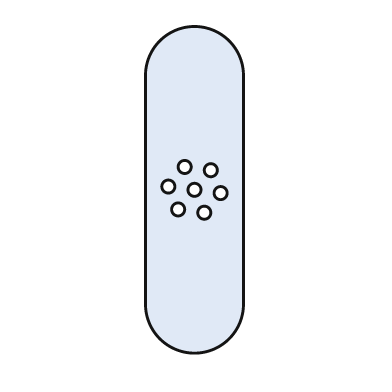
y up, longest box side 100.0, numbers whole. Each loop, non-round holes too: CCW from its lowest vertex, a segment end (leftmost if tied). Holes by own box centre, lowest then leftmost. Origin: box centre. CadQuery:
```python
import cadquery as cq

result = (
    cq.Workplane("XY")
    .moveTo(-15.0, -35.0)
    .threePointArc((0.0, -50.0), (15.0, -35.0))
    .lineTo(15.0, 35.0)
    .threePointArc((0.0, 50.0), (-15.0, 35.0))
    .close()
    .moveTo(3.0, -7.0)
    .circle(2.0)
    .moveTo(-5.0, -6.0)
    .circle(2.0)
    .moveTo(8.0, -1.0)
    .circle(2.0)
    .moveTo(0.0, 0.0)
    .circle(2.0)
    .moveTo(-8.0, 1.0)
    .circle(2.0)
    .moveTo(5.0, 6.0)
    .circle(2.0)
    .moveTo(-3.0, 7.0)
    .circle(2.0)
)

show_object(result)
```